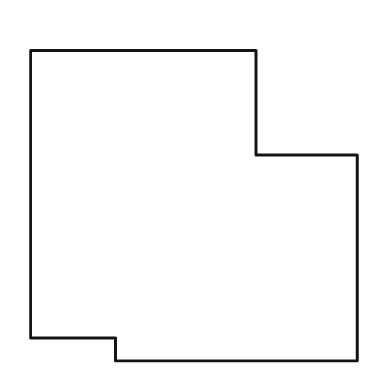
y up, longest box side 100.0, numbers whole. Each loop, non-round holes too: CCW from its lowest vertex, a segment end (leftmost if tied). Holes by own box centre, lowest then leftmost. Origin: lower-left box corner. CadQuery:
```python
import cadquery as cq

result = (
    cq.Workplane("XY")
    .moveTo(26.0, 0.0)
    .lineTo(100.0, 0.0)
    .lineTo(100.0, 63.0)
    .lineTo(69.0, 63.0)
    .lineTo(69.0, 95.0)
    .lineTo(0.0, 95.0)
    .lineTo(0.0, 7.0)
    .lineTo(26.0, 7.0)
    .close()
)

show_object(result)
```